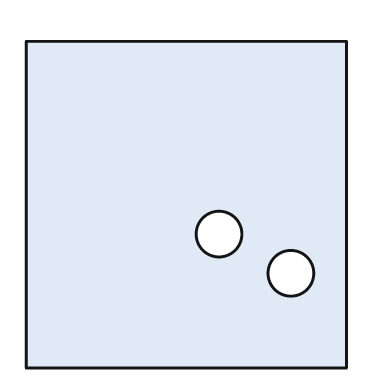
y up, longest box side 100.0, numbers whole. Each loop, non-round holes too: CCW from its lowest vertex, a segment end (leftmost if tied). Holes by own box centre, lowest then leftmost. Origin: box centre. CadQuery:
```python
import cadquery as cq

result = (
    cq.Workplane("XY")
    .moveTo(-49.0, -50.0)
    .lineTo(49.0, -50.0)
    .lineTo(49.0, 50.0)
    .lineTo(-49.0, 50.0)
    .close()
    .moveTo(32.0, -21.0)
    .circle(7.0)
    .moveTo(10.0, -9.0)
    .circle(7.0)
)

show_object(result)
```